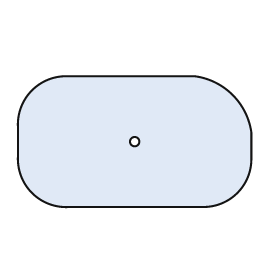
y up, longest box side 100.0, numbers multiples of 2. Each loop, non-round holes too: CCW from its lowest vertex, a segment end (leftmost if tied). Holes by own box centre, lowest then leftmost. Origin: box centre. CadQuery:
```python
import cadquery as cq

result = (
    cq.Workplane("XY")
    .moveTo(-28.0, -28.0)
    .lineTo(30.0, -28.0)
    .threePointArc((44.0, -22.0), (50.0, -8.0))
    .lineTo(50.0, 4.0)
    .threePointArc((42.0, 20.0), (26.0, 28.0))
    .lineTo(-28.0, 28.0)
    .threePointArc((-44.0, 22.0), (-50.0, 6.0))
    .lineTo(-50.0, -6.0)
    .threePointArc((-44.0, -22.0), (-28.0, -28.0))
    .close()
    .moveTo(0.0, 0.0)
    .circle(2.0)
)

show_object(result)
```